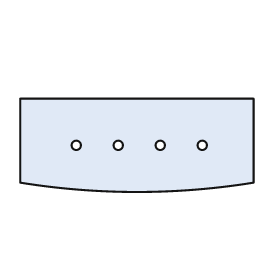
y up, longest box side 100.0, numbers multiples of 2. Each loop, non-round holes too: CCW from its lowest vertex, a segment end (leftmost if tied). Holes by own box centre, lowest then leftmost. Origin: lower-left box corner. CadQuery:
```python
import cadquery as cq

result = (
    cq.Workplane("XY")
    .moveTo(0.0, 4.0)
    .threePointArc((50.0, 0.0), (100.0, 4.0))
    .lineTo(100.0, 40.0)
    .lineTo(0.0, 40.0)
    .close()
    .moveTo(24.0, 20.0)
    .circle(2.0)
    .moveTo(42.0, 20.0)
    .circle(2.0)
    .moveTo(60.0, 20.0)
    .circle(2.0)
    .moveTo(78.0, 20.0)
    .circle(2.0)
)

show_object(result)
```